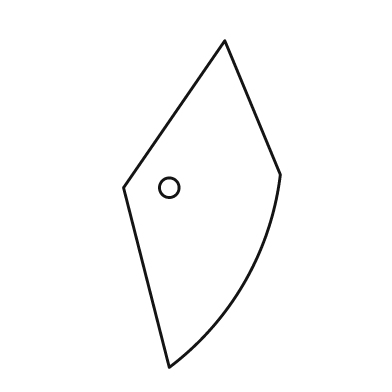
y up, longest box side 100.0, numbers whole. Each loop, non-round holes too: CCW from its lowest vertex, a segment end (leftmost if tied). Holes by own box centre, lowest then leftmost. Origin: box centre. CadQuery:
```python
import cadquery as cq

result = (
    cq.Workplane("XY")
    .moveTo(-10.0, -50.0)
    .threePointArc((13.0, -24.0), (24.0, 9.0))
    .lineTo(7.0, 50.0)
    .lineTo(-24.0, 5.0)
    .close()
    .moveTo(-10.0, 5.0)
    .circle(3.0)
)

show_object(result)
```